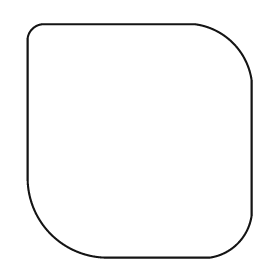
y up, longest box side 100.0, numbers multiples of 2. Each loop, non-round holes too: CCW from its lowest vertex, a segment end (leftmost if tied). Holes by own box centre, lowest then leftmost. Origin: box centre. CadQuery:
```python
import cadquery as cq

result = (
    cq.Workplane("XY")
    .moveTo(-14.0, -50.0)
    .lineTo(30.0, -50.0)
    .threePointArc((42.0, -44.0), (48.0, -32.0))
    .lineTo(48.0, 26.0)
    .threePointArc((40.0, 42.0), (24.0, 50.0))
    .lineTo(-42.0, 50.0)
    .threePointArc((-46.0, 48.0), (-48.0, 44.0))
    .lineTo(-48.0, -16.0)
    .threePointArc((-38.0, -40.0), (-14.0, -50.0))
    .close()
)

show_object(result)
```